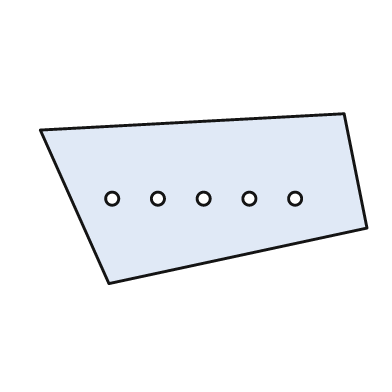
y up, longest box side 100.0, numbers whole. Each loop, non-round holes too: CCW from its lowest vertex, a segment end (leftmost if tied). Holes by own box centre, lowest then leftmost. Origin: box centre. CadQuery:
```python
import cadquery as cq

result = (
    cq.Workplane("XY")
    .moveTo(-29.0, -26.0)
    .lineTo(50.0, -9.0)
    .lineTo(43.0, 26.0)
    .lineTo(-50.0, 21.0)
    .close()
    .moveTo(-28.0, 0.0)
    .circle(2.0)
    .moveTo(-14.0, 0.0)
    .circle(2.0)
    .moveTo(0.0, 0.0)
    .circle(2.0)
    .moveTo(14.0, 0.0)
    .circle(2.0)
    .moveTo(28.0, 0.0)
    .circle(2.0)
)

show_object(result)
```